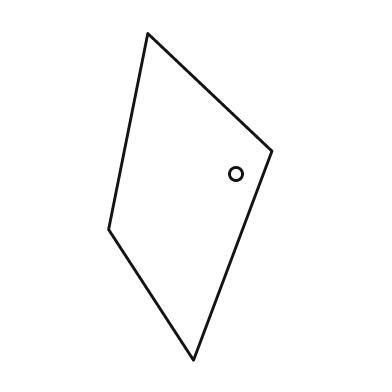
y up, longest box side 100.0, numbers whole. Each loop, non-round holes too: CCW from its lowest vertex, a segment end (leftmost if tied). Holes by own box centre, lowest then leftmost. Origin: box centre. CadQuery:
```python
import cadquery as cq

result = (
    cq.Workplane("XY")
    .moveTo(1.0, -50.0)
    .lineTo(25.0, 14.0)
    .lineTo(-13.0, 50.0)
    .lineTo(-25.0, -10.0)
    .close()
    .moveTo(14.0, 7.0)
    .circle(2.0)
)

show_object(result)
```